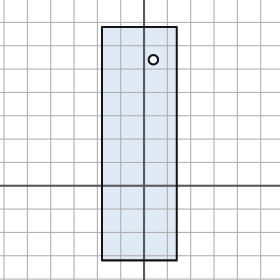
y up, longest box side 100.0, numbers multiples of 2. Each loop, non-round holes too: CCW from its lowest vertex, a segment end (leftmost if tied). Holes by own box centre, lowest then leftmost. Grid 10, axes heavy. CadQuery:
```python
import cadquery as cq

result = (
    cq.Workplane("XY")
    .moveTo(-18.0, -32.0)
    .lineTo(14.0, -32.0)
    .lineTo(14.0, 68.0)
    .lineTo(-18.0, 68.0)
    .close()
    .moveTo(4.0, 54.0)
    .circle(2.0)
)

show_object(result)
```